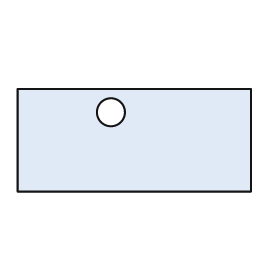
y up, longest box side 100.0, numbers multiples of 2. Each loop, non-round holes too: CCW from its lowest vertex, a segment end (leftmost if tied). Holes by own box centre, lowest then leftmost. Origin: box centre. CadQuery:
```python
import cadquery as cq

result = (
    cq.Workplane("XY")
    .moveTo(-50.0, -22.0)
    .lineTo(50.0, -22.0)
    .lineTo(50.0, 22.0)
    .lineTo(-50.0, 22.0)
    .close()
    .moveTo(-10.0, 12.0)
    .circle(6.0)
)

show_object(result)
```